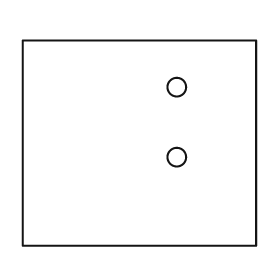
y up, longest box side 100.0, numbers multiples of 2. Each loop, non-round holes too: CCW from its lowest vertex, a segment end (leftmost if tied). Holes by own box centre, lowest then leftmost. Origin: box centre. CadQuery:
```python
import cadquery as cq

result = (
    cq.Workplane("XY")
    .moveTo(-50.0, -44.0)
    .lineTo(50.0, -44.0)
    .lineTo(50.0, 44.0)
    .lineTo(-50.0, 44.0)
    .close()
    .moveTo(16.0, -6.0)
    .circle(4.0)
    .moveTo(16.0, 24.0)
    .circle(4.0)
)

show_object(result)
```